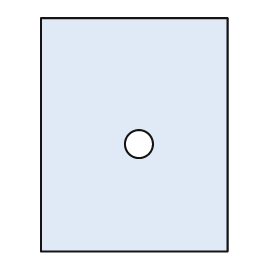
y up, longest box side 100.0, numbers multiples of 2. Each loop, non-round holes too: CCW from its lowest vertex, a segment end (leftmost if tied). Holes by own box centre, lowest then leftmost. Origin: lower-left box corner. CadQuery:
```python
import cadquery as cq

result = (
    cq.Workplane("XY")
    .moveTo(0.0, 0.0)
    .lineTo(80.0, 0.0)
    .lineTo(80.0, 100.0)
    .lineTo(0.0, 100.0)
    .close()
    .moveTo(42.0, 46.0)
    .circle(6.0)
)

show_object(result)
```